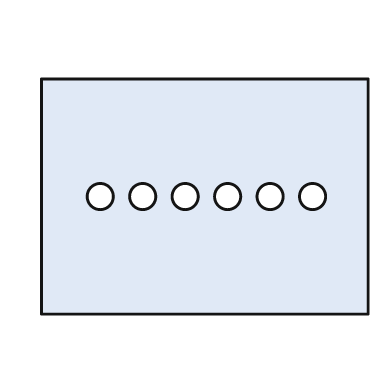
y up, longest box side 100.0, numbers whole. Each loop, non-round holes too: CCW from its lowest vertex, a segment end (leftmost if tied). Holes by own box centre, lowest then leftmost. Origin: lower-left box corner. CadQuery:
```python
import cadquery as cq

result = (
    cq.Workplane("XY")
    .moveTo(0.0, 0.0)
    .lineTo(100.0, 0.0)
    .lineTo(100.0, 72.0)
    .lineTo(0.0, 72.0)
    .close()
    .moveTo(18.0, 36.0)
    .circle(4.0)
    .moveTo(31.0, 36.0)
    .circle(4.0)
    .moveTo(44.0, 36.0)
    .circle(4.0)
    .moveTo(57.0, 36.0)
    .circle(4.0)
    .moveTo(70.0, 36.0)
    .circle(4.0)
    .moveTo(83.0, 36.0)
    .circle(4.0)
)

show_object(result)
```